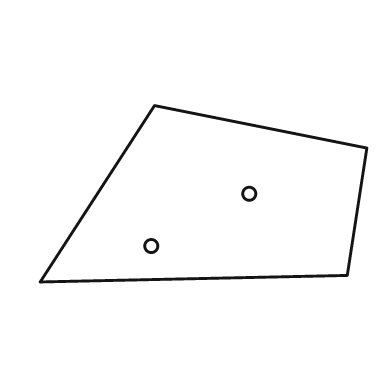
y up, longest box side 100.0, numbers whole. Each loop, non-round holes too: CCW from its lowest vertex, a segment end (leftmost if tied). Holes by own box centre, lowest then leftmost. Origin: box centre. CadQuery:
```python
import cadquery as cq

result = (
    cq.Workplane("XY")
    .moveTo(-50.0, -27.0)
    .lineTo(44.0, -25.0)
    .lineTo(50.0, 14.0)
    .lineTo(-15.0, 27.0)
    .close()
    .moveTo(-16.0, -16.0)
    .circle(2.0)
    .moveTo(14.0, 0.0)
    .circle(2.0)
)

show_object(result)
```